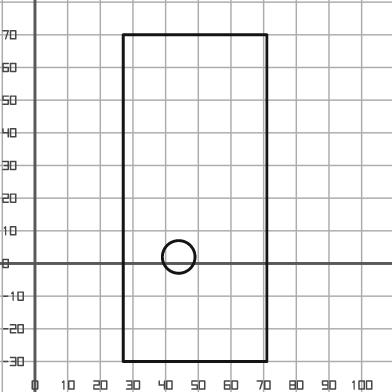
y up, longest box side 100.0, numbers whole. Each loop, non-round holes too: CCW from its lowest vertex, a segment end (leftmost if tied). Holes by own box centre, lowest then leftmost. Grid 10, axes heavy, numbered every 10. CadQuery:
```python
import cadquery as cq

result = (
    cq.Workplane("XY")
    .moveTo(27.0, -30.0)
    .lineTo(71.0, -30.0)
    .lineTo(71.0, 70.0)
    .lineTo(27.0, 70.0)
    .close()
    .moveTo(44.0, 2.0)
    .circle(5.0)
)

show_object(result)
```